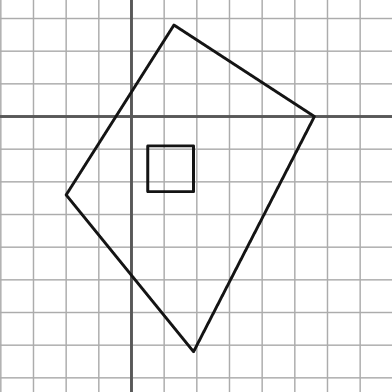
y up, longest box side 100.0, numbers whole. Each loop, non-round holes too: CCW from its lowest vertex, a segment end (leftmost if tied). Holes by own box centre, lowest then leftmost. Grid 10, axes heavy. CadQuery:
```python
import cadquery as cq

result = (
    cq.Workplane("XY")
    .moveTo(19.0, -72.0)
    .lineTo(56.0, 0.0)
    .lineTo(13.0, 28.0)
    .lineTo(-20.0, -24.0)
    .close()
    .moveTo(5.0, -23.0)
    .lineTo(19.0, -23.0)
    .lineTo(19.0, -9.0)
    .lineTo(5.0, -9.0)
    .close()
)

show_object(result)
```